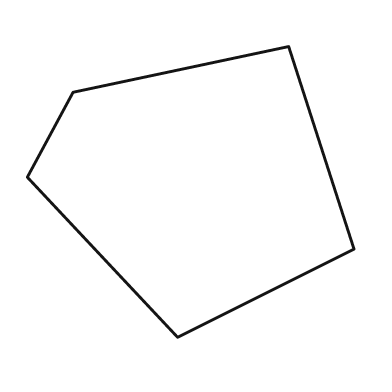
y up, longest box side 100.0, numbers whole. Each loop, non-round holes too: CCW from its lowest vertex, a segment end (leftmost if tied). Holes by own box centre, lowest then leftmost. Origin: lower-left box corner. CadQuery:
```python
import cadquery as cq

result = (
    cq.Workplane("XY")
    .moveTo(46.0, 0.0)
    .lineTo(100.0, 27.0)
    .lineTo(80.0, 89.0)
    .lineTo(14.0, 75.0)
    .lineTo(0.0, 49.0)
    .close()
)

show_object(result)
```